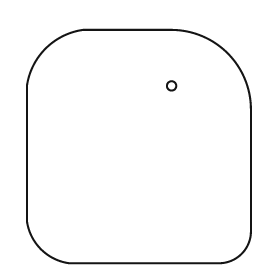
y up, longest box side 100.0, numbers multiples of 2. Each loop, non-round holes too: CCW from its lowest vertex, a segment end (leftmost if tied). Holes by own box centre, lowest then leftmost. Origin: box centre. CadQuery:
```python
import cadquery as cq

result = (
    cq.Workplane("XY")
    .moveTo(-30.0, -50.0)
    .lineTo(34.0, -50.0)
    .threePointArc((44.0, -46.0), (48.0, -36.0))
    .lineTo(48.0, 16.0)
    .threePointArc((38.0, 40.0), (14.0, 50.0))
    .lineTo(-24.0, 50.0)
    .threePointArc((-40.0, 42.0), (-48.0, 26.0))
    .lineTo(-48.0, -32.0)
    .threePointArc((-42.0, -44.0), (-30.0, -50.0))
    .close()
    .moveTo(14.0, 26.0)
    .circle(2.0)
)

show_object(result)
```